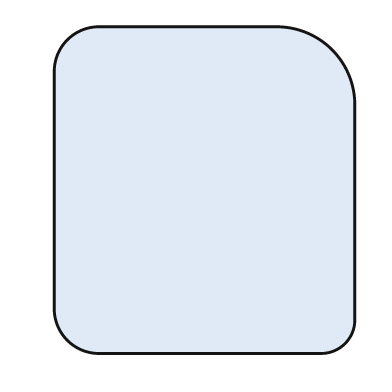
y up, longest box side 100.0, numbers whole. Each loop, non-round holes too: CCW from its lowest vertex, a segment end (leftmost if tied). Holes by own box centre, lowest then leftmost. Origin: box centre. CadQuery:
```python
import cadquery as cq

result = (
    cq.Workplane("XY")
    .moveTo(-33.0, -50.0)
    .lineTo(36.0, -50.0)
    .threePointArc((43.0, -47.0), (46.0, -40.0))
    .lineTo(46.0, 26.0)
    .threePointArc((39.0, 43.0), (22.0, 50.0))
    .lineTo(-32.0, 50.0)
    .threePointArc((-42.0, 46.0), (-46.0, 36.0))
    .lineTo(-46.0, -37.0)
    .threePointArc((-42.0, -46.0), (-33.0, -50.0))
    .close()
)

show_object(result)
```